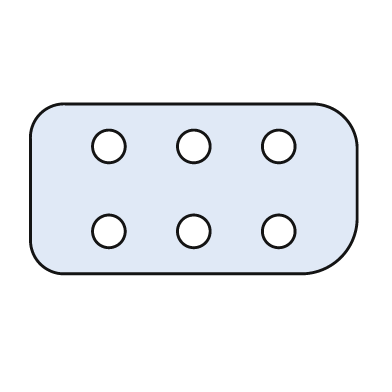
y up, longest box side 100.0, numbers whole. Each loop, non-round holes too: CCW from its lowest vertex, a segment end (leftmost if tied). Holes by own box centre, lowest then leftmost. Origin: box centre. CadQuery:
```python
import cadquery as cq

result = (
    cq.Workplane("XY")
    .moveTo(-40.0, -26.0)
    .lineTo(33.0, -26.0)
    .threePointArc((45.0, -21.0), (50.0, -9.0))
    .lineTo(50.0, 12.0)
    .threePointArc((46.0, 22.0), (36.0, 26.0))
    .lineTo(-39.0, 26.0)
    .threePointArc((-47.0, 23.0), (-50.0, 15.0))
    .lineTo(-50.0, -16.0)
    .threePointArc((-47.0, -23.0), (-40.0, -26.0))
    .close()
    .moveTo(-26.0, -13.0)
    .circle(5.0)
    .moveTo(0.0, -13.0)
    .circle(5.0)
    .moveTo(26.0, -13.0)
    .circle(5.0)
    .moveTo(-26.0, 13.0)
    .circle(5.0)
    .moveTo(0.0, 13.0)
    .circle(5.0)
    .moveTo(26.0, 13.0)
    .circle(5.0)
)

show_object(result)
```